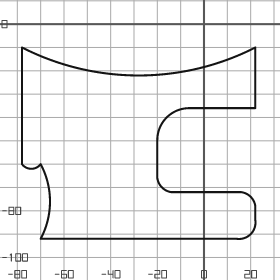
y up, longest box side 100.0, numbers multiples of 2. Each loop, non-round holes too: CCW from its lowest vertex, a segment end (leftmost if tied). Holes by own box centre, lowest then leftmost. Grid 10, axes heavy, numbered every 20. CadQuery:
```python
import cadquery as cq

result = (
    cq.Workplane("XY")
    .moveTo(-70.0, -92.0)
    .lineTo(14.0, -92.0)
    .threePointArc((20.0, -90.0), (22.0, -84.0))
    .lineTo(22.0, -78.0)
    .threePointArc((20.0, -74.0), (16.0, -72.0))
    .lineTo(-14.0, -72.0)
    .threePointArc((-18.0, -70.0), (-20.0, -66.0))
    .lineTo(-20.0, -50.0)
    .threePointArc((-16.0, -40.0), (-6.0, -36.0))
    .lineTo(22.0, -36.0)
    .lineTo(22.0, -10.0)
    .threePointArc((-28.0, -22.0), (-78.0, -10.0))
    .lineTo(-78.0, -60.0)
    .threePointArc((-74.0, -62.0), (-70.0, -60.0))
    .threePointArc((-66.0, -76.0), (-70.0, -92.0))
    .close()
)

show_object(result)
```